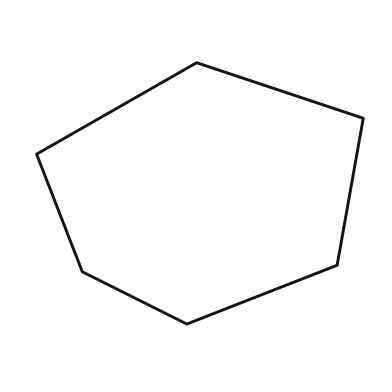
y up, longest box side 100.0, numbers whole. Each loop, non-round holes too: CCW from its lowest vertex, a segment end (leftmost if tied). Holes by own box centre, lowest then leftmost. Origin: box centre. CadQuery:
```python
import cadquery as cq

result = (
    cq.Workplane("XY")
    .moveTo(-4.0, -40.0)
    .lineTo(42.0, -22.0)
    .lineTo(50.0, 23.0)
    .lineTo(-1.0, 40.0)
    .lineTo(-50.0, 12.0)
    .lineTo(-36.0, -24.0)
    .close()
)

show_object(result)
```